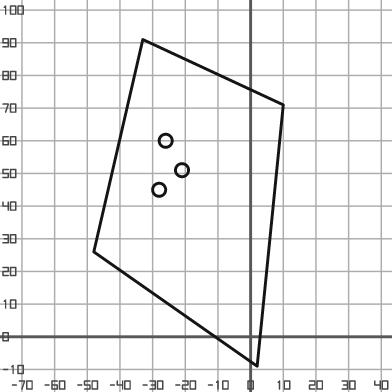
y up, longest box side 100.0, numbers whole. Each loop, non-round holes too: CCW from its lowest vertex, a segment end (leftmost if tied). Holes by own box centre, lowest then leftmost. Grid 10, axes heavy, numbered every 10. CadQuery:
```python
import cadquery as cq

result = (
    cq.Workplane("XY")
    .moveTo(2.0, -9.0)
    .lineTo(10.0, 71.0)
    .lineTo(-33.0, 91.0)
    .lineTo(-48.0, 26.0)
    .close()
    .moveTo(-28.0, 45.0)
    .circle(2.0)
    .moveTo(-21.0, 51.0)
    .circle(2.0)
    .moveTo(-26.0, 60.0)
    .circle(2.0)
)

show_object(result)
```